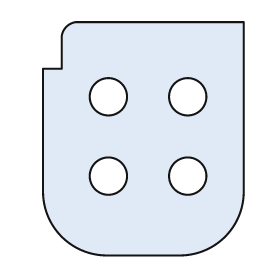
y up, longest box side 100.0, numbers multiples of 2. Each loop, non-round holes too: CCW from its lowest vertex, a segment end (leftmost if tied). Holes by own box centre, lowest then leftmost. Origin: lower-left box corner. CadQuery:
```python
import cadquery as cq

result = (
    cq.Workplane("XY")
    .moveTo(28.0, 0.0)
    .lineTo(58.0, 0.0)
    .threePointArc((78.0, 8.0), (86.0, 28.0))
    .lineTo(86.0, 100.0)
    .lineTo(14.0, 100.0)
    .threePointArc((10.0, 98.0), (8.0, 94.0))
    .lineTo(8.0, 80.0)
    .lineTo(0.0, 80.0)
    .lineTo(0.0, 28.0)
    .threePointArc((8.0, 8.0), (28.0, 0.0))
    .close()
    .moveTo(28.0, 34.0)
    .circle(8.0)
    .moveTo(62.0, 34.0)
    .circle(8.0)
    .moveTo(28.0, 68.0)
    .circle(8.0)
    .moveTo(62.0, 68.0)
    .circle(8.0)
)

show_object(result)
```